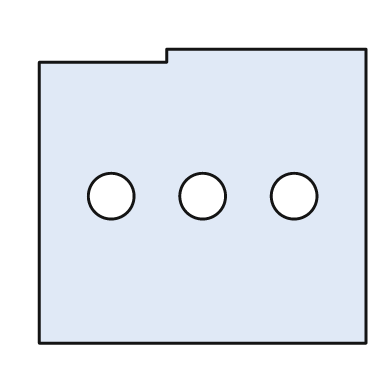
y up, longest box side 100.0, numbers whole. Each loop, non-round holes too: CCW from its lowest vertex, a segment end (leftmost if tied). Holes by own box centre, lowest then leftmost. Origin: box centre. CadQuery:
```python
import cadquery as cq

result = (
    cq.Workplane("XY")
    .moveTo(-50.0, -45.0)
    .lineTo(50.0, -45.0)
    .lineTo(50.0, 45.0)
    .lineTo(-11.0, 45.0)
    .lineTo(-11.0, 41.0)
    .lineTo(-50.0, 41.0)
    .close()
    .moveTo(-28.0, 0.0)
    .circle(7.0)
    .moveTo(0.0, 0.0)
    .circle(7.0)
    .moveTo(28.0, 0.0)
    .circle(7.0)
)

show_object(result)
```